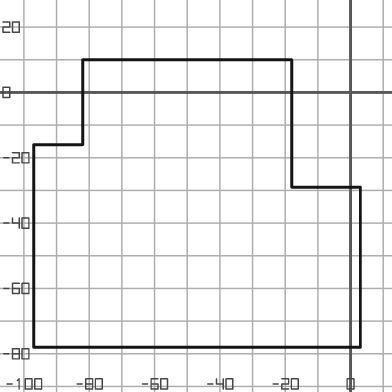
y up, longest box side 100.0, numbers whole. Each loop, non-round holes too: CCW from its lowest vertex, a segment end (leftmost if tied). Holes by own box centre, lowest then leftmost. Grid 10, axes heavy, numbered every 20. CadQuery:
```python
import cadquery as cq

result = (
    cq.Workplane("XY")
    .moveTo(-97.0, -78.0)
    .lineTo(3.0, -78.0)
    .lineTo(3.0, -29.0)
    .lineTo(-18.0, -29.0)
    .lineTo(-18.0, 10.0)
    .lineTo(-82.0, 10.0)
    .lineTo(-82.0, -16.0)
    .lineTo(-97.0, -16.0)
    .close()
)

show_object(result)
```